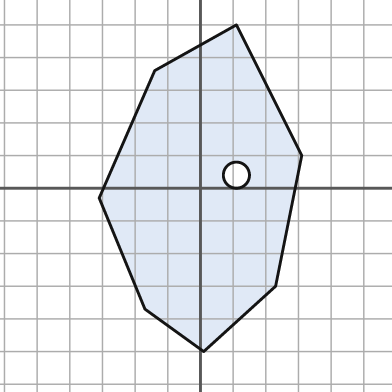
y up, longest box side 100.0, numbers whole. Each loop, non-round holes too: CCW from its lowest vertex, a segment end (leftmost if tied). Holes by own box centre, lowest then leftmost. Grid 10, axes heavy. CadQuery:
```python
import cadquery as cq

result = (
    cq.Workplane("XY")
    .moveTo(1.0, -50.0)
    .lineTo(23.0, -30.0)
    .lineTo(31.0, 10.0)
    .lineTo(11.0, 50.0)
    .lineTo(-14.0, 36.0)
    .lineTo(-31.0, -3.0)
    .lineTo(-17.0, -37.0)
    .close()
    .moveTo(11.0, 4.0)
    .circle(4.0)
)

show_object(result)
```